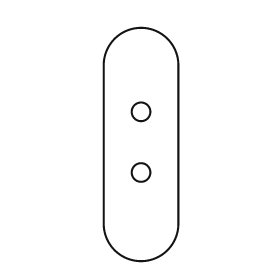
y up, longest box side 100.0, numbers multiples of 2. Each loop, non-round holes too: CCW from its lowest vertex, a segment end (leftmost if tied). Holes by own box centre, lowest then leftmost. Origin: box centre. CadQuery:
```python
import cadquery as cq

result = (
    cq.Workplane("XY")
    .moveTo(-16.0, -34.0)
    .threePointArc((0.0, -50.0), (16.0, -34.0))
    .lineTo(16.0, 34.0)
    .threePointArc((0.0, 50.0), (-16.0, 34.0))
    .close()
    .moveTo(0.0, -12.0)
    .circle(4.0)
    .moveTo(0.0, 14.0)
    .circle(4.0)
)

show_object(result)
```